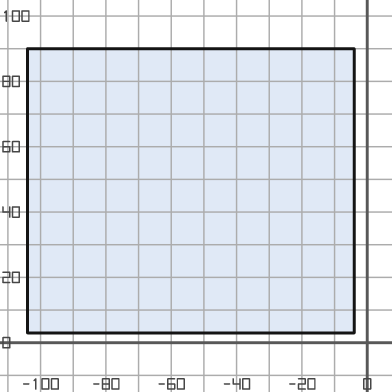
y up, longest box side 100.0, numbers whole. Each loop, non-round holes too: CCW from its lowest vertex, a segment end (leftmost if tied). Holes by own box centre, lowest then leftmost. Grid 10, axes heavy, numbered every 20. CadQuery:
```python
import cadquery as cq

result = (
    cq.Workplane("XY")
    .moveTo(-104.0, 3.0)
    .lineTo(-4.0, 3.0)
    .lineTo(-4.0, 90.0)
    .lineTo(-104.0, 90.0)
    .close()
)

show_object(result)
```